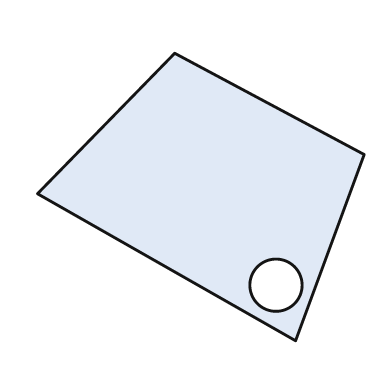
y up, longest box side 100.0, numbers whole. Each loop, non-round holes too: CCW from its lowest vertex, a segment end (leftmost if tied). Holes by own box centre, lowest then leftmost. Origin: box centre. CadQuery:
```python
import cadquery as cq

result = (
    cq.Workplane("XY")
    .moveTo(29.0, -44.0)
    .lineTo(50.0, 13.0)
    .lineTo(-8.0, 44.0)
    .lineTo(-50.0, 1.0)
    .close()
    .moveTo(23.0, -27.0)
    .circle(8.0)
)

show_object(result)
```